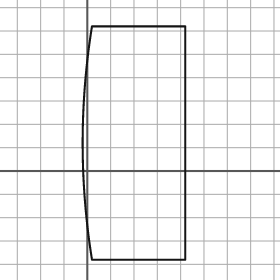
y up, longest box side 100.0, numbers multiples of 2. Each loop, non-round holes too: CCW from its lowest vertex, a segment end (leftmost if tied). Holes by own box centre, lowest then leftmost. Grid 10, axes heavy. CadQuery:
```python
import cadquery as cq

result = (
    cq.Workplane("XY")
    .moveTo(2.0, -38.0)
    .lineTo(42.0, -38.0)
    .lineTo(42.0, 62.0)
    .lineTo(2.0, 62.0)
    .threePointArc((-2.0, 12.0), (2.0, -38.0))
    .close()
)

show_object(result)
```